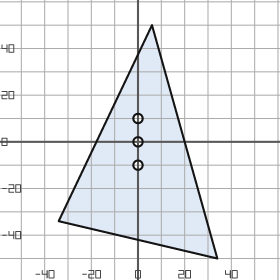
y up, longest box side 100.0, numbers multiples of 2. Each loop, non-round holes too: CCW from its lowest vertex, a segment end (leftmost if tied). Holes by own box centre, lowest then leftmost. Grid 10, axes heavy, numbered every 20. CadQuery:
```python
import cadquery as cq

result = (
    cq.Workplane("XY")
    .moveTo(34.0, -50.0)
    .lineTo(6.0, 50.0)
    .lineTo(-34.0, -34.0)
    .close()
    .moveTo(0.0, -10.0)
    .circle(2.0)
    .moveTo(0.0, 0.0)
    .circle(2.0)
    .moveTo(0.0, 10.0)
    .circle(2.0)
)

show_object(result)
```